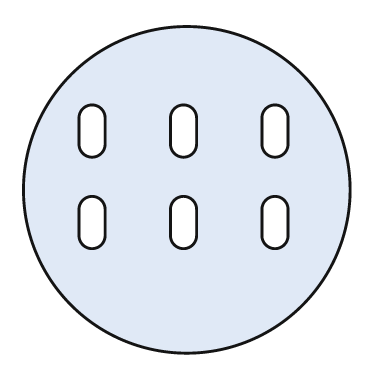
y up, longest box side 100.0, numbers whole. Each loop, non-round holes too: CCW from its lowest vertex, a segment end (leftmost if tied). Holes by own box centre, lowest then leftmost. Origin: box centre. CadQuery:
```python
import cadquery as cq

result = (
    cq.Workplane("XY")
    .moveTo(0.0, 0.0)
    .circle(50.0)
    .moveTo(-33.0, -14.0)
    .threePointArc((-29.0, -18.0), (-25.0, -14.0))
    .lineTo(-25.0, -6.0)
    .threePointArc((-29.0, -2.0), (-33.0, -6.0))
    .close()
    .moveTo(-5.0, -14.0)
    .threePointArc((-1.0, -18.0), (3.0, -14.0))
    .lineTo(3.0, -6.0)
    .threePointArc((-1.0, -2.0), (-5.0, -6.0))
    .close()
    .moveTo(23.0, -14.0)
    .threePointArc((27.0, -18.0), (31.0, -14.0))
    .lineTo(31.0, -6.0)
    .threePointArc((27.0, -2.0), (23.0, -6.0))
    .close()
    .moveTo(-33.0, 14.0)
    .threePointArc((-29.0, 10.0), (-25.0, 14.0))
    .lineTo(-25.0, 22.0)
    .threePointArc((-29.0, 26.0), (-33.0, 22.0))
    .close()
    .moveTo(-5.0, 14.0)
    .threePointArc((-1.0, 10.0), (3.0, 14.0))
    .lineTo(3.0, 22.0)
    .threePointArc((-1.0, 26.0), (-5.0, 22.0))
    .close()
    .moveTo(23.0, 14.0)
    .threePointArc((27.0, 10.0), (31.0, 14.0))
    .lineTo(31.0, 22.0)
    .threePointArc((27.0, 26.0), (23.0, 22.0))
    .close()
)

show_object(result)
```